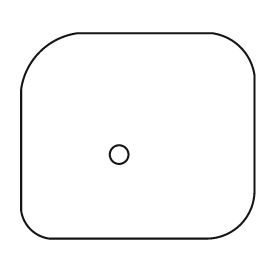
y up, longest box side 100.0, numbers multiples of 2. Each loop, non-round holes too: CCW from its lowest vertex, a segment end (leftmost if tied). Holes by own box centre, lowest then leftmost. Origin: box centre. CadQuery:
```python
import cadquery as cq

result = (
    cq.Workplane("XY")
    .moveTo(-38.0, -44.0)
    .lineTo(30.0, -44.0)
    .threePointArc((44.0, -38.0), (50.0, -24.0))
    .lineTo(50.0, 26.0)
    .threePointArc((44.0, 38.0), (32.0, 44.0))
    .lineTo(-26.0, 44.0)
    .threePointArc((-42.0, 36.0), (-50.0, 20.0))
    .lineTo(-50.0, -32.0)
    .threePointArc((-46.0, -40.0), (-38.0, -44.0))
    .close()
    .moveTo(-8.0, -8.0)
    .circle(4.0)
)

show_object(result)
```